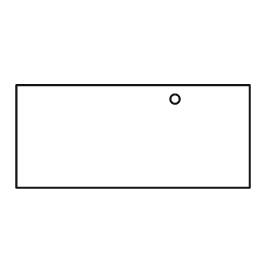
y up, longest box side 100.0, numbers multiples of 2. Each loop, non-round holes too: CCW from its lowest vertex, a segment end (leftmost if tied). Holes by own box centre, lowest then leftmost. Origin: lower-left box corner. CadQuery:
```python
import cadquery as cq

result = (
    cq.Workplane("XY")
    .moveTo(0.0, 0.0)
    .lineTo(100.0, 0.0)
    .lineTo(100.0, 44.0)
    .lineTo(0.0, 44.0)
    .close()
    .moveTo(68.0, 38.0)
    .circle(2.0)
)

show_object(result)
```